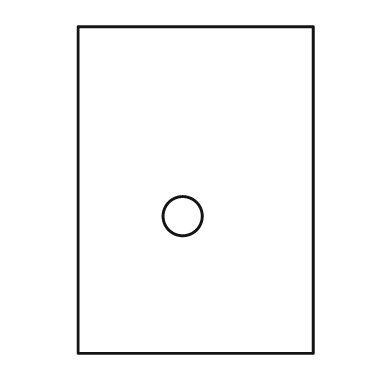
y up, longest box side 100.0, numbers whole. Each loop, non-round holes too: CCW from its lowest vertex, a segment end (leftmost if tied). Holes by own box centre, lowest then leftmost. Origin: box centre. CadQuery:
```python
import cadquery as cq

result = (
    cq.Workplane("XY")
    .moveTo(-36.0, -50.0)
    .lineTo(36.0, -50.0)
    .lineTo(36.0, 50.0)
    .lineTo(-36.0, 50.0)
    .close()
    .moveTo(-4.0, -8.0)
    .circle(6.0)
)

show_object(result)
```